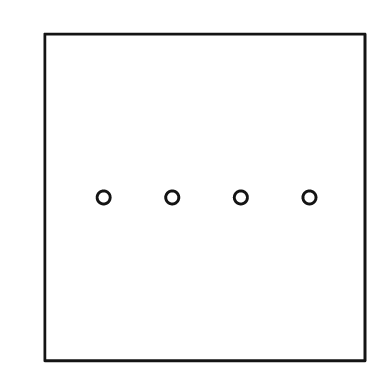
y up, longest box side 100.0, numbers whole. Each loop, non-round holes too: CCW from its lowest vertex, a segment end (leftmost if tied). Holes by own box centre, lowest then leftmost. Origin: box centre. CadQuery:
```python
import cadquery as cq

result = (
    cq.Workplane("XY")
    .moveTo(-49.0, -50.0)
    .lineTo(49.0, -50.0)
    .lineTo(49.0, 50.0)
    .lineTo(-49.0, 50.0)
    .close()
    .moveTo(-31.0, 0.0)
    .circle(2.0)
    .moveTo(-10.0, 0.0)
    .circle(2.0)
    .moveTo(11.0, 0.0)
    .circle(2.0)
    .moveTo(32.0, 0.0)
    .circle(2.0)
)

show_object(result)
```